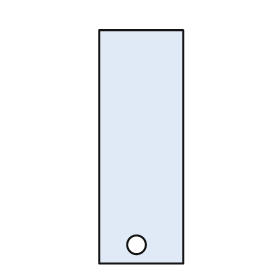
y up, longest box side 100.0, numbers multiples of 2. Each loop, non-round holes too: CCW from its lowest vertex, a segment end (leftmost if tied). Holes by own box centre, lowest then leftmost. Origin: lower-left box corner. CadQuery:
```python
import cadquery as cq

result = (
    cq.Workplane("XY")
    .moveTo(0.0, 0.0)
    .lineTo(36.0, 0.0)
    .lineTo(36.0, 100.0)
    .lineTo(0.0, 100.0)
    .close()
    .moveTo(16.0, 8.0)
    .circle(4.0)
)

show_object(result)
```